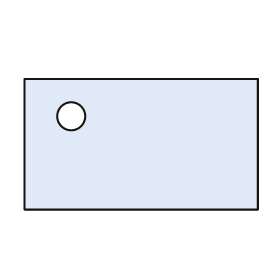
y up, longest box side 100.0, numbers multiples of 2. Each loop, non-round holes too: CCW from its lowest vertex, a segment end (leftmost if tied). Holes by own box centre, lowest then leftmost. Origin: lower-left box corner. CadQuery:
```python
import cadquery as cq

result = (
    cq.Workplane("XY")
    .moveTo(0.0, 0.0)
    .lineTo(100.0, 0.0)
    .lineTo(100.0, 56.0)
    .lineTo(0.0, 56.0)
    .close()
    .moveTo(20.0, 40.0)
    .circle(6.0)
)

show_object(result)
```